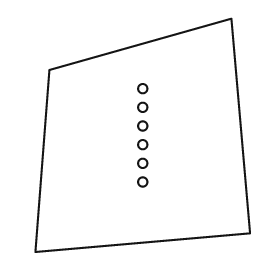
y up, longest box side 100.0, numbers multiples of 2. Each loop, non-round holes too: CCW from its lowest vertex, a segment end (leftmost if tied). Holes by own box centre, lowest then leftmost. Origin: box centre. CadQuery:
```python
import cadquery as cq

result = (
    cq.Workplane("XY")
    .moveTo(-46.0, -50.0)
    .lineTo(46.0, -42.0)
    .lineTo(38.0, 50.0)
    .lineTo(-40.0, 28.0)
    .close()
    .moveTo(0.0, -20.0)
    .circle(2.0)
    .moveTo(0.0, -12.0)
    .circle(2.0)
    .moveTo(0.0, -4.0)
    .circle(2.0)
    .moveTo(0.0, 4.0)
    .circle(2.0)
    .moveTo(0.0, 12.0)
    .circle(2.0)
    .moveTo(0.0, 20.0)
    .circle(2.0)
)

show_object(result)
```